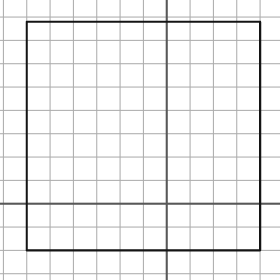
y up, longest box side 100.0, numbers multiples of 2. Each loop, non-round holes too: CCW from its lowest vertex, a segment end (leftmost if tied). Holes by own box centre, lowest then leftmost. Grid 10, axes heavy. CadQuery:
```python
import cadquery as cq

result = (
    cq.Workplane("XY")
    .moveTo(-60.0, -20.0)
    .lineTo(40.0, -20.0)
    .lineTo(40.0, 78.0)
    .lineTo(-60.0, 78.0)
    .close()
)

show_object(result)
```